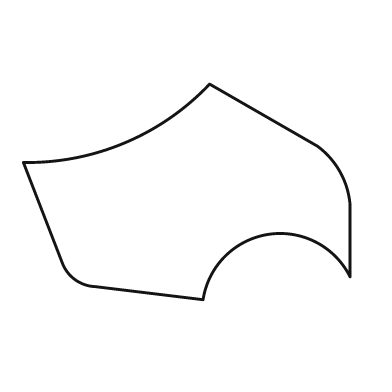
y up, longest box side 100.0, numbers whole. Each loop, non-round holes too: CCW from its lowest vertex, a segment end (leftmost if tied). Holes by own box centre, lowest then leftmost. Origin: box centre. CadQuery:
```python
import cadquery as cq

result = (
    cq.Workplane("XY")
    .moveTo(5.0, -33.0)
    .threePointArc((25.0, -13.0), (50.0, -26.0))
    .lineTo(50.0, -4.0)
    .threePointArc((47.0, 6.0), (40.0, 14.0))
    .lineTo(7.0, 33.0)
    .threePointArc((-19.0, 15.0), (-50.0, 9.0))
    .lineTo(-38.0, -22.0)
    .threePointArc((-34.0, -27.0), (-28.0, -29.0))
    .close()
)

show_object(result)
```